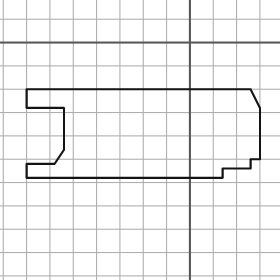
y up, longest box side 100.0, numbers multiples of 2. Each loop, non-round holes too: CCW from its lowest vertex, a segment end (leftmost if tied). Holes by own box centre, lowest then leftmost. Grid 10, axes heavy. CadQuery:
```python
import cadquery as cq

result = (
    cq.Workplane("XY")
    .moveTo(-70.0, -58.0)
    .lineTo(14.0, -58.0)
    .lineTo(14.0, -54.0)
    .lineTo(26.0, -54.0)
    .lineTo(26.0, -50.0)
    .lineTo(30.0, -50.0)
    .lineTo(30.0, -28.0)
    .lineTo(26.0, -20.0)
    .lineTo(-70.0, -20.0)
    .lineTo(-70.0, -28.0)
    .lineTo(-54.0, -28.0)
    .lineTo(-54.0, -46.0)
    .lineTo(-58.0, -52.0)
    .lineTo(-70.0, -52.0)
    .close()
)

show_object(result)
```